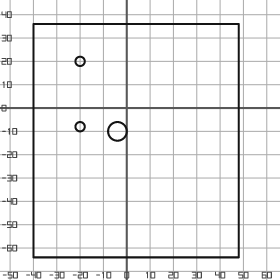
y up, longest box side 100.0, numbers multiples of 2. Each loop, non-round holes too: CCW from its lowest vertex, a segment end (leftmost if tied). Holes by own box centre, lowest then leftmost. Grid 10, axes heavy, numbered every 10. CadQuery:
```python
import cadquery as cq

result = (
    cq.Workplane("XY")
    .moveTo(-40.0, -64.0)
    .lineTo(48.0, -64.0)
    .lineTo(48.0, 36.0)
    .lineTo(-40.0, 36.0)
    .close()
    .moveTo(-4.0, -10.0)
    .circle(4.0)
    .moveTo(-20.0, -8.0)
    .circle(2.0)
    .moveTo(-20.0, 20.0)
    .circle(2.0)
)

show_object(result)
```